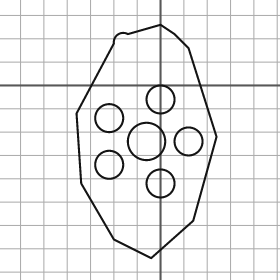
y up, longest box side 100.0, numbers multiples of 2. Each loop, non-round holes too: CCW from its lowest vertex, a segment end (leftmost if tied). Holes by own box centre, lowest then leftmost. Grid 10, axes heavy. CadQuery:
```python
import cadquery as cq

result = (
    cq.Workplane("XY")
    .moveTo(-4.0, -74.0)
    .lineTo(14.0, -58.0)
    .lineTo(24.0, -22.0)
    .lineTo(12.0, 16.0)
    .lineTo(6.0, 22.0)
    .lineTo(0.0, 26.0)
    .lineTo(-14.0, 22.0)
    .threePointArc((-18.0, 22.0), (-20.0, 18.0))
    .lineTo(-36.0, -12.0)
    .lineTo(-34.0, -42.0)
    .lineTo(-20.0, -66.0)
    .close()
    .moveTo(0.0, -42.0)
    .circle(6.0)
    .moveTo(-22.0, -34.0)
    .circle(6.0)
    .moveTo(-6.0, -24.0)
    .circle(8.0)
    .moveTo(12.0, -24.0)
    .circle(6.0)
    .moveTo(-22.0, -14.0)
    .circle(6.0)
    .moveTo(0.0, -6.0)
    .circle(6.0)
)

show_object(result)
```